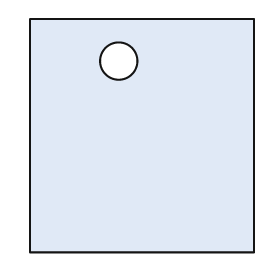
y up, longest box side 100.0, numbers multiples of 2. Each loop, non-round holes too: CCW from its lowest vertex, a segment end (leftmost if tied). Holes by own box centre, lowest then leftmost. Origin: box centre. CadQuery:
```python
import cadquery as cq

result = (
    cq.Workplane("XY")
    .moveTo(-48.0, -50.0)
    .lineTo(48.0, -50.0)
    .lineTo(48.0, 50.0)
    .lineTo(-48.0, 50.0)
    .close()
    .moveTo(-10.0, 32.0)
    .circle(8.0)
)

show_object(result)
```